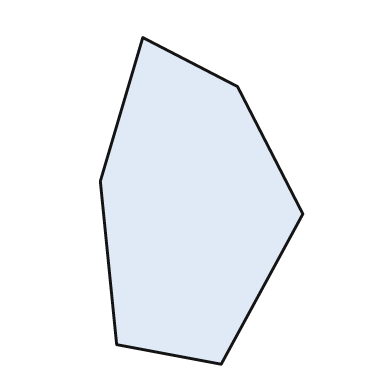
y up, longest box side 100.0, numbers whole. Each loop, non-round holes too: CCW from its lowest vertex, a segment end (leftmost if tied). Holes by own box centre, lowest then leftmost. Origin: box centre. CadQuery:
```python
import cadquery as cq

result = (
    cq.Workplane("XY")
    .moveTo(6.0, -50.0)
    .lineTo(31.0, -4.0)
    .lineTo(11.0, 35.0)
    .lineTo(-18.0, 50.0)
    .lineTo(-31.0, 6.0)
    .lineTo(-26.0, -44.0)
    .close()
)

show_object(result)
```